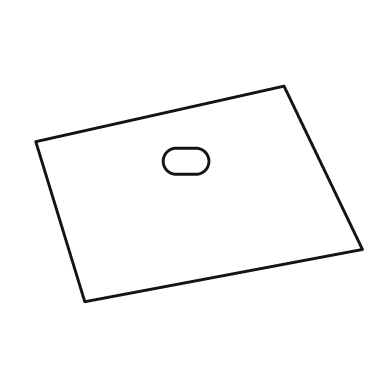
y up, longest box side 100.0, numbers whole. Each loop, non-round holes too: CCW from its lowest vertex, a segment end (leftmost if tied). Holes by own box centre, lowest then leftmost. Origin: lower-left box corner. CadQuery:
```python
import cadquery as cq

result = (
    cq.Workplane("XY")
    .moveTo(15.0, 0.0)
    .lineTo(100.0, 16.0)
    .lineTo(76.0, 66.0)
    .lineTo(0.0, 49.0)
    .close()
    .moveTo(43.0, 39.0)
    .lineTo(49.0, 39.0)
    .threePointArc((53.0, 43.0), (49.0, 47.0))
    .lineTo(43.0, 47.0)
    .threePointArc((39.0, 43.0), (43.0, 39.0))
    .close()
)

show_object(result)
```